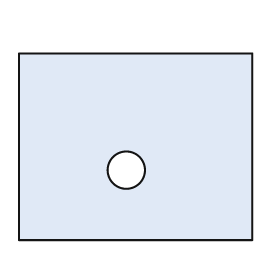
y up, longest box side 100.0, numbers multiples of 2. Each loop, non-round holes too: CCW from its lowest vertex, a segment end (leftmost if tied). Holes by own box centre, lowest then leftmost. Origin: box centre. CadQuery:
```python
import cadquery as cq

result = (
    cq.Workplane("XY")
    .moveTo(-50.0, -40.0)
    .lineTo(50.0, -40.0)
    .lineTo(50.0, 40.0)
    .lineTo(-50.0, 40.0)
    .close()
    .moveTo(-4.0, -10.0)
    .circle(8.0)
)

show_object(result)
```